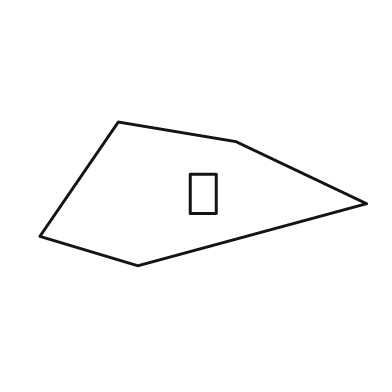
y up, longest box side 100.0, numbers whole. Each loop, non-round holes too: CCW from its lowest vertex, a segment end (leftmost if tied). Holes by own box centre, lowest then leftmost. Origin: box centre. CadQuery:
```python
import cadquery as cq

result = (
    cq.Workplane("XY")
    .moveTo(-20.0, -22.0)
    .lineTo(50.0, -3.0)
    .lineTo(10.0, 16.0)
    .lineTo(-26.0, 22.0)
    .lineTo(-50.0, -13.0)
    .close()
    .moveTo(-4.0, -6.0)
    .lineTo(4.0, -6.0)
    .lineTo(4.0, 6.0)
    .lineTo(-4.0, 6.0)
    .close()
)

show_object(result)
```